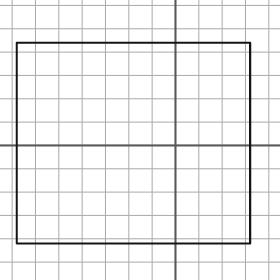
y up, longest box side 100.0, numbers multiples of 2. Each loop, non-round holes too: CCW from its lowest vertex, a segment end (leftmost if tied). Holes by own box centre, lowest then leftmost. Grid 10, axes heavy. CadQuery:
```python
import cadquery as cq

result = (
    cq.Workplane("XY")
    .moveTo(-68.0, -42.0)
    .lineTo(32.0, -42.0)
    .lineTo(32.0, 44.0)
    .lineTo(-68.0, 44.0)
    .close()
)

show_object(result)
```